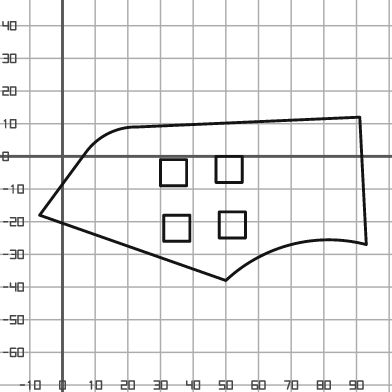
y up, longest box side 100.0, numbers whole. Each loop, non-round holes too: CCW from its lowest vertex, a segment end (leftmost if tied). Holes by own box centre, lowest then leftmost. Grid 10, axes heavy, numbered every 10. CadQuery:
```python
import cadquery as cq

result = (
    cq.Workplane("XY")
    .moveTo(50.0, -38.0)
    .threePointArc((70.0, -27.0), (93.0, -27.0))
    .lineTo(91.0, 12.0)
    .lineTo(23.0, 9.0)
    .threePointArc((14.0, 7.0), (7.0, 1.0))
    .lineTo(-7.0, -18.0)
    .close()
    .moveTo(31.0, -26.0)
    .lineTo(39.0, -26.0)
    .lineTo(39.0, -18.0)
    .lineTo(31.0, -18.0)
    .close()
    .moveTo(48.0, -25.0)
    .lineTo(56.0, -25.0)
    .lineTo(56.0, -17.0)
    .lineTo(48.0, -17.0)
    .close()
    .moveTo(30.0, -9.0)
    .lineTo(38.0, -9.0)
    .lineTo(38.0, -1.0)
    .lineTo(30.0, -1.0)
    .close()
    .moveTo(47.0, -8.0)
    .lineTo(55.0, -8.0)
    .lineTo(55.0, 0.0)
    .lineTo(47.0, 0.0)
    .close()
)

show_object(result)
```